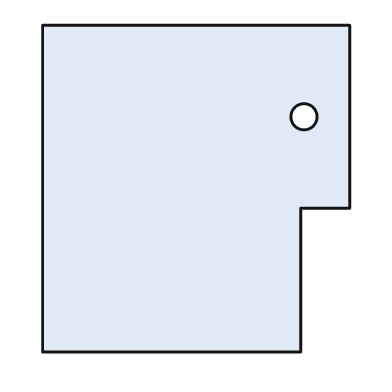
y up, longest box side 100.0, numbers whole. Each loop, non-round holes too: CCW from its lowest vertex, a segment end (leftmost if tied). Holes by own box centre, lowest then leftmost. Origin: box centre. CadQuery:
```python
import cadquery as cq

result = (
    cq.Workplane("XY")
    .moveTo(-47.0, -50.0)
    .lineTo(32.0, -50.0)
    .lineTo(32.0, -6.0)
    .lineTo(47.0, -6.0)
    .lineTo(47.0, 50.0)
    .lineTo(-47.0, 50.0)
    .close()
    .moveTo(33.0, 22.0)
    .circle(4.0)
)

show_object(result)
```